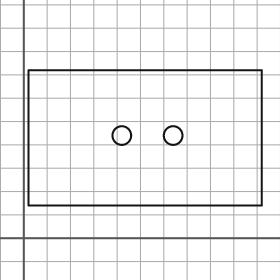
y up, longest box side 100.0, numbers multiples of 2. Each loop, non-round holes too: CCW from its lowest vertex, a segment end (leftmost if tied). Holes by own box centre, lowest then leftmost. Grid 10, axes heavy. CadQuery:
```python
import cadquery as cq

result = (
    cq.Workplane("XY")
    .moveTo(2.0, 14.0)
    .lineTo(102.0, 14.0)
    .lineTo(102.0, 72.0)
    .lineTo(2.0, 72.0)
    .close()
    .moveTo(42.0, 44.0)
    .circle(4.0)
    .moveTo(64.0, 44.0)
    .circle(4.0)
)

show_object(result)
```